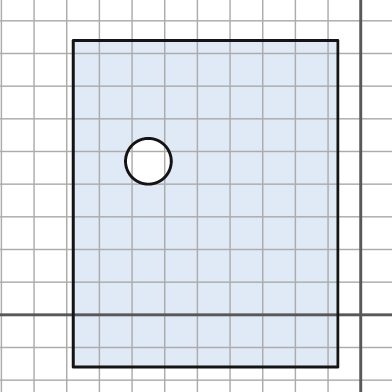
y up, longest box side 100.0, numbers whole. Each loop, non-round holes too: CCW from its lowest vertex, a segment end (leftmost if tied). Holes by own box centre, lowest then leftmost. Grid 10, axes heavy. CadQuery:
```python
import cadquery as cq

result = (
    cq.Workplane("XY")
    .moveTo(-88.0, -16.0)
    .lineTo(-7.0, -16.0)
    .lineTo(-7.0, 84.0)
    .lineTo(-88.0, 84.0)
    .close()
    .moveTo(-65.0, 47.0)
    .circle(7.0)
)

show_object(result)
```